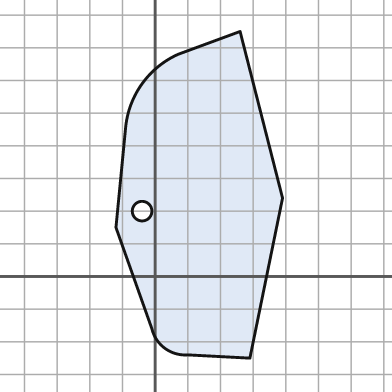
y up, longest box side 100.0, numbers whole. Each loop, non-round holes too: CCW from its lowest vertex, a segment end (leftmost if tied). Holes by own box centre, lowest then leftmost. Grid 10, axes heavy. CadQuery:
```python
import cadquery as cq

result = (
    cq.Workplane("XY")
    .moveTo(29.0, -25.0)
    .lineTo(39.0, 24.0)
    .lineTo(26.0, 75.0)
    .lineTo(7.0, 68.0)
    .threePointArc((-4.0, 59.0), (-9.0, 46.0))
    .lineTo(-12.0, 15.0)
    .lineTo(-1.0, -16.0)
    .threePointArc((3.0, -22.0), (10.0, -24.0))
    .close()
    .moveTo(-4.0, 20.0)
    .circle(3.0)
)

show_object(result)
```